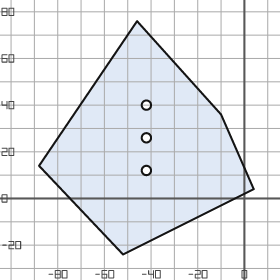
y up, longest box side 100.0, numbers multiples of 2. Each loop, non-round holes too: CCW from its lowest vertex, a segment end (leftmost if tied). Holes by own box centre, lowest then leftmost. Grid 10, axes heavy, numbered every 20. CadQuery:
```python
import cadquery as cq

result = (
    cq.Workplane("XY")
    .moveTo(-52.0, -24.0)
    .lineTo(4.0, 4.0)
    .lineTo(-10.0, 36.0)
    .lineTo(-46.0, 76.0)
    .lineTo(-88.0, 14.0)
    .close()
    .moveTo(-42.0, 12.0)
    .circle(2.0)
    .moveTo(-42.0, 26.0)
    .circle(2.0)
    .moveTo(-42.0, 40.0)
    .circle(2.0)
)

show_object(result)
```